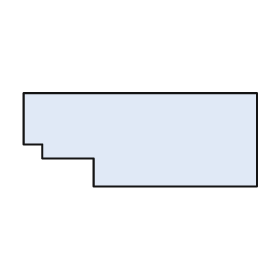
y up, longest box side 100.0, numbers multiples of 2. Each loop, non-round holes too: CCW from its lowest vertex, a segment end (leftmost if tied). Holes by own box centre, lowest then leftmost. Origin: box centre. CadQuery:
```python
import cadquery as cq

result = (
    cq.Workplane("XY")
    .moveTo(-20.0, -20.0)
    .lineTo(50.0, -20.0)
    .lineTo(50.0, 20.0)
    .lineTo(-50.0, 20.0)
    .lineTo(-50.0, -2.0)
    .lineTo(-42.0, -2.0)
    .lineTo(-42.0, -8.0)
    .lineTo(-20.0, -8.0)
    .close()
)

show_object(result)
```